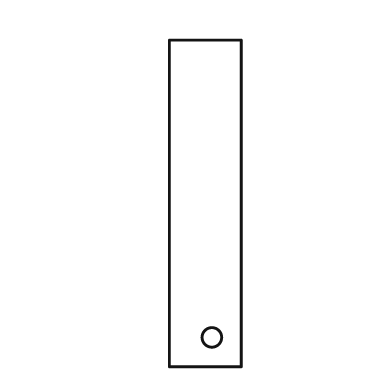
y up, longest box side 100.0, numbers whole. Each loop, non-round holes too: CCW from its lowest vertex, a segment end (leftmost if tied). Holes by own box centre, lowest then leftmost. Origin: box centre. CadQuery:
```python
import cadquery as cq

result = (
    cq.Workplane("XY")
    .moveTo(-11.0, -50.0)
    .lineTo(11.0, -50.0)
    .lineTo(11.0, 50.0)
    .lineTo(-11.0, 50.0)
    .close()
    .moveTo(2.0, -41.0)
    .circle(3.0)
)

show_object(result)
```